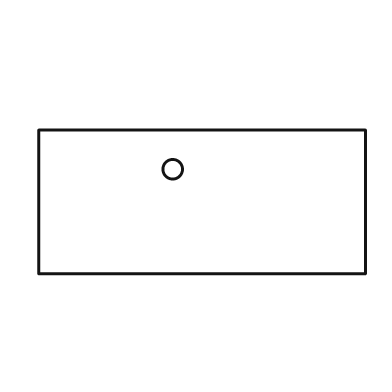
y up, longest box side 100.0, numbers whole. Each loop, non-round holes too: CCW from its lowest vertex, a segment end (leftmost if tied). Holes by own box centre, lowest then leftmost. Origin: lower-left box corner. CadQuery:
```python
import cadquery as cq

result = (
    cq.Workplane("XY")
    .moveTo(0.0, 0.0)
    .lineTo(100.0, 0.0)
    .lineTo(100.0, 44.0)
    .lineTo(0.0, 44.0)
    .close()
    .moveTo(41.0, 32.0)
    .circle(3.0)
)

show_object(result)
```